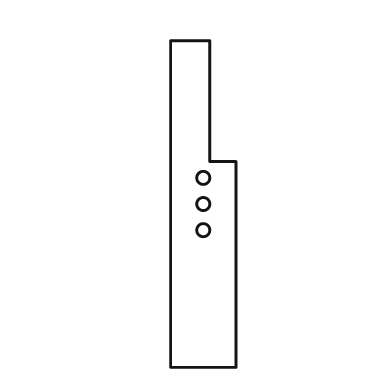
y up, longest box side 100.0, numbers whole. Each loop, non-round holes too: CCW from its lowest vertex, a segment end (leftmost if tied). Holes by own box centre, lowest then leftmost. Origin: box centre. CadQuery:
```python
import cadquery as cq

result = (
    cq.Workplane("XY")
    .moveTo(-10.0, -50.0)
    .lineTo(10.0, -50.0)
    .lineTo(10.0, 13.0)
    .lineTo(2.0, 13.0)
    .lineTo(2.0, 50.0)
    .lineTo(-10.0, 50.0)
    .close()
    .moveTo(0.0, -8.0)
    .circle(2.0)
    .moveTo(0.0, 0.0)
    .circle(2.0)
    .moveTo(0.0, 8.0)
    .circle(2.0)
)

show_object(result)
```